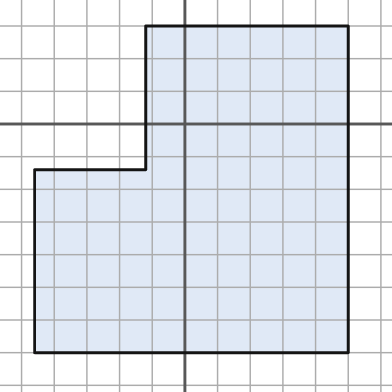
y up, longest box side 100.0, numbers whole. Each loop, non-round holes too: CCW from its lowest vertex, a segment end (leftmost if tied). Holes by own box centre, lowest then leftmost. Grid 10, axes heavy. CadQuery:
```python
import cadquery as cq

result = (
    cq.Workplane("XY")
    .moveTo(-46.0, -70.0)
    .lineTo(50.0, -70.0)
    .lineTo(50.0, 30.0)
    .lineTo(-12.0, 30.0)
    .lineTo(-12.0, -14.0)
    .lineTo(-46.0, -14.0)
    .close()
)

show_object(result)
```